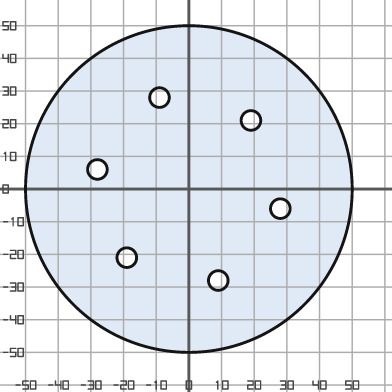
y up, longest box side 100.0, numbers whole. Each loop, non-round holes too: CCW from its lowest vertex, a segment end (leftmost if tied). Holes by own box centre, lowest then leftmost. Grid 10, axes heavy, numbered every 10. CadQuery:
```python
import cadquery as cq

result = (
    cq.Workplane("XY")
    .moveTo(0.0, 0.0)
    .circle(50.0)
    .moveTo(9.0, -28.0)
    .circle(3.0)
    .moveTo(-19.0, -21.0)
    .circle(3.0)
    .moveTo(28.0, -6.0)
    .circle(3.0)
    .moveTo(-28.0, 6.0)
    .circle(3.0)
    .moveTo(19.0, 21.0)
    .circle(3.0)
    .moveTo(-9.0, 28.0)
    .circle(3.0)
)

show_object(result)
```